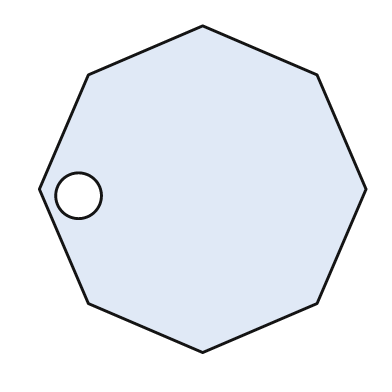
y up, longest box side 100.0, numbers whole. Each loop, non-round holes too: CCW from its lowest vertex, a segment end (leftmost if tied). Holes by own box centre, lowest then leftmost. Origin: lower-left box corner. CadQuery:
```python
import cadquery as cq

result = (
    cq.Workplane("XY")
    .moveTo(50.0, 0.0)
    .lineTo(85.0, 15.0)
    .lineTo(100.0, 50.0)
    .lineTo(85.0, 85.0)
    .lineTo(50.0, 100.0)
    .lineTo(15.0, 85.0)
    .lineTo(0.0, 50.0)
    .lineTo(15.0, 15.0)
    .close()
    .moveTo(12.0, 48.0)
    .circle(7.0)
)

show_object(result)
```